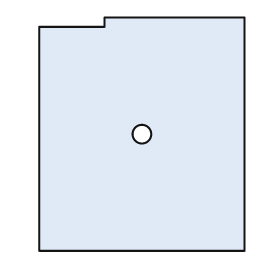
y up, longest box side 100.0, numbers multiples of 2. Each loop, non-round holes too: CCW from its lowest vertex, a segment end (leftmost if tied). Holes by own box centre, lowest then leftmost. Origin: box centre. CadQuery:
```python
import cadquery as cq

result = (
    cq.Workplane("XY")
    .moveTo(-44.0, -50.0)
    .lineTo(44.0, -50.0)
    .lineTo(44.0, 50.0)
    .lineTo(-16.0, 50.0)
    .lineTo(-16.0, 46.0)
    .lineTo(-44.0, 46.0)
    .close()
    .moveTo(0.0, 0.0)
    .circle(4.0)
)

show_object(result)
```